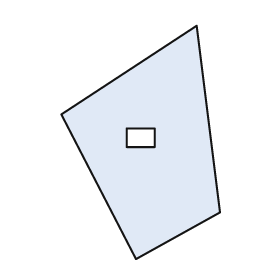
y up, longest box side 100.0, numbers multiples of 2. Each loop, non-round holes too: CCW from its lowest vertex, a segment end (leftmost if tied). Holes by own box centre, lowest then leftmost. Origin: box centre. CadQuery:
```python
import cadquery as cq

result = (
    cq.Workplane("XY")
    .moveTo(-2.0, -50.0)
    .lineTo(34.0, -30.0)
    .lineTo(24.0, 50.0)
    .lineTo(-34.0, 12.0)
    .close()
    .moveTo(-6.0, -2.0)
    .lineTo(6.0, -2.0)
    .lineTo(6.0, 6.0)
    .lineTo(-6.0, 6.0)
    .close()
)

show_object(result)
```